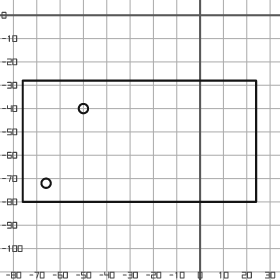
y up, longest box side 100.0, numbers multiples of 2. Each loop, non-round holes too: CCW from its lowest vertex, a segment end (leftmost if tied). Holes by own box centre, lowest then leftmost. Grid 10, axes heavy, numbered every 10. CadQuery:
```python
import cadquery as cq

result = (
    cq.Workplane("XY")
    .moveTo(-76.0, -80.0)
    .lineTo(24.0, -80.0)
    .lineTo(24.0, -28.0)
    .lineTo(-76.0, -28.0)
    .close()
    .moveTo(-66.0, -72.0)
    .circle(2.0)
    .moveTo(-50.0, -40.0)
    .circle(2.0)
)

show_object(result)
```